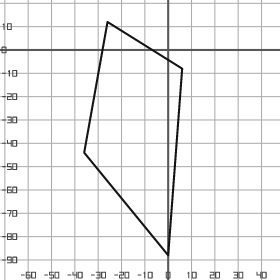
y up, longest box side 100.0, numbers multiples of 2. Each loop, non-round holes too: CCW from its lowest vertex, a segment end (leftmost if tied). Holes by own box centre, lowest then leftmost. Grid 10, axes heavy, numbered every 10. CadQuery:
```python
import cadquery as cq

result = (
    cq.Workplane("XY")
    .moveTo(0.0, -88.0)
    .lineTo(6.0, -8.0)
    .lineTo(-26.0, 12.0)
    .lineTo(-36.0, -44.0)
    .close()
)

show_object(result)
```